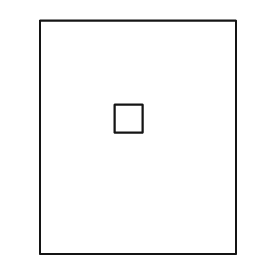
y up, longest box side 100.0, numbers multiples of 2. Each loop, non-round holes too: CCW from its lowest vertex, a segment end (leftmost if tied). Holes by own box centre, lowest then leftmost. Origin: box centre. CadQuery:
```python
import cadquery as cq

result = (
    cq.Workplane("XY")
    .moveTo(-42.0, -50.0)
    .lineTo(42.0, -50.0)
    .lineTo(42.0, 50.0)
    .lineTo(-42.0, 50.0)
    .close()
    .moveTo(-10.0, 2.0)
    .lineTo(2.0, 2.0)
    .lineTo(2.0, 14.0)
    .lineTo(-10.0, 14.0)
    .close()
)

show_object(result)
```